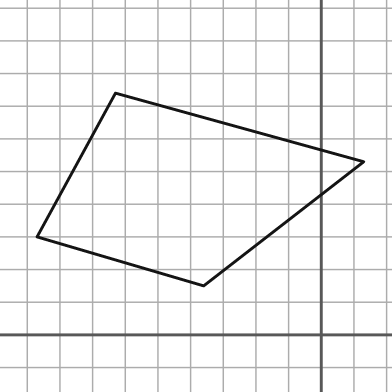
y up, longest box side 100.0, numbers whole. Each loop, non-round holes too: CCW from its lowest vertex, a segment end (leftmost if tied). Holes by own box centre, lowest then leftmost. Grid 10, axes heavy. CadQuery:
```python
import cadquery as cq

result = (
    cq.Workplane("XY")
    .moveTo(-36.0, 15.0)
    .lineTo(13.0, 53.0)
    .lineTo(-63.0, 74.0)
    .lineTo(-87.0, 30.0)
    .close()
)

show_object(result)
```